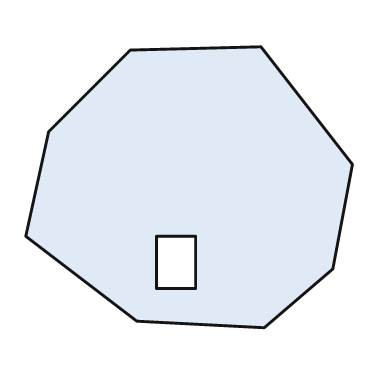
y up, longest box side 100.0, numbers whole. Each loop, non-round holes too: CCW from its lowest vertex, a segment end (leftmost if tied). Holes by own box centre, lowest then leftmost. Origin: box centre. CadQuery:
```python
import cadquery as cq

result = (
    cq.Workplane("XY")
    .moveTo(23.0, -43.0)
    .lineTo(44.0, -25.0)
    .lineTo(50.0, 7.0)
    .lineTo(22.0, 43.0)
    .lineTo(-18.0, 42.0)
    .lineTo(-43.0, 17.0)
    .lineTo(-50.0, -15.0)
    .lineTo(-16.0, -41.0)
    .close()
    .moveTo(-10.0, -31.0)
    .lineTo(2.0, -31.0)
    .lineTo(2.0, -15.0)
    .lineTo(-10.0, -15.0)
    .close()
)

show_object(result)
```